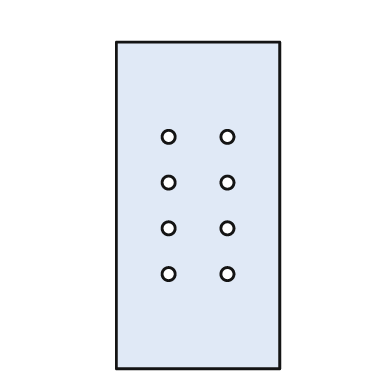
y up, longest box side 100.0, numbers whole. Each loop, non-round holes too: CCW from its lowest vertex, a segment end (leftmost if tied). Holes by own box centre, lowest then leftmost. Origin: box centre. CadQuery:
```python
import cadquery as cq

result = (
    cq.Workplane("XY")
    .moveTo(-25.0, -50.0)
    .lineTo(25.0, -50.0)
    .lineTo(25.0, 50.0)
    .lineTo(-25.0, 50.0)
    .close()
    .moveTo(-9.0, -21.0)
    .circle(2.0)
    .moveTo(9.0, -21.0)
    .circle(2.0)
    .moveTo(-9.0, -7.0)
    .circle(2.0)
    .moveTo(9.0, -7.0)
    .circle(2.0)
    .moveTo(-9.0, 7.0)
    .circle(2.0)
    .moveTo(9.0, 7.0)
    .circle(2.0)
    .moveTo(-9.0, 21.0)
    .circle(2.0)
    .moveTo(9.0, 21.0)
    .circle(2.0)
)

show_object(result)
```